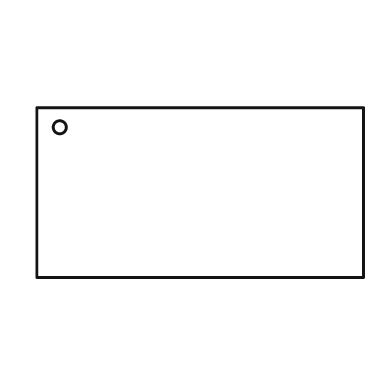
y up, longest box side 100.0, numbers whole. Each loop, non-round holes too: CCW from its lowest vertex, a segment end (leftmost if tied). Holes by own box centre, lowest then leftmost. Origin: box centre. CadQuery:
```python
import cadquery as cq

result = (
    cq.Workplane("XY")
    .moveTo(-50.0, -26.0)
    .lineTo(50.0, -26.0)
    .lineTo(50.0, 26.0)
    .lineTo(-50.0, 26.0)
    .close()
    .moveTo(-43.0, 20.0)
    .circle(2.0)
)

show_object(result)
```